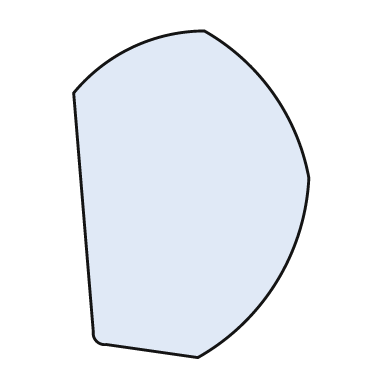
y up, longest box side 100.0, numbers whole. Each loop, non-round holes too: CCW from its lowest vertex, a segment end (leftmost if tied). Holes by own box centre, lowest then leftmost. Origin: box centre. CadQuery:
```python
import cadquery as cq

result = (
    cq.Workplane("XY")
    .moveTo(2.0, -50.0)
    .threePointArc((26.0, -27.0), (36.0, 5.0))
    .threePointArc((25.0, 31.0), (4.0, 50.0))
    .threePointArc((-18.0, 45.0), (-36.0, 31.0))
    .lineTo(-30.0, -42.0)
    .threePointArc((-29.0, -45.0), (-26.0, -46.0))
    .close()
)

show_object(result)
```